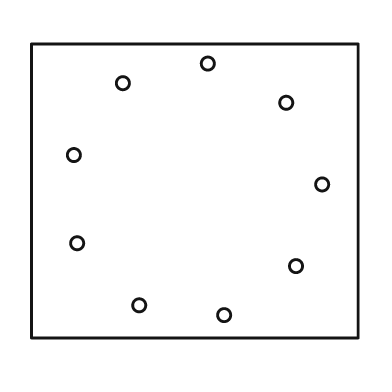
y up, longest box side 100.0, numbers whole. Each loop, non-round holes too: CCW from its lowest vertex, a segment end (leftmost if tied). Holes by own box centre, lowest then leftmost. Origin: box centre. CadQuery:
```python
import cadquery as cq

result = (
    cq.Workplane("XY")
    .moveTo(-50.0, -45.0)
    .lineTo(50.0, -45.0)
    .lineTo(50.0, 45.0)
    .lineTo(-50.0, 45.0)
    .close()
    .moveTo(9.0, -38.0)
    .circle(2.0)
    .moveTo(-17.0, -35.0)
    .circle(2.0)
    .moveTo(31.0, -23.0)
    .circle(2.0)
    .moveTo(-36.0, -16.0)
    .circle(2.0)
    .moveTo(39.0, 2.0)
    .circle(2.0)
    .moveTo(-37.0, 11.0)
    .circle(2.0)
    .moveTo(28.0, 27.0)
    .circle(2.0)
    .moveTo(-22.0, 33.0)
    .circle(2.0)
    .moveTo(4.0, 39.0)
    .circle(2.0)
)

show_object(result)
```